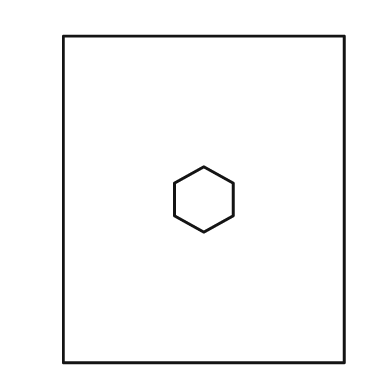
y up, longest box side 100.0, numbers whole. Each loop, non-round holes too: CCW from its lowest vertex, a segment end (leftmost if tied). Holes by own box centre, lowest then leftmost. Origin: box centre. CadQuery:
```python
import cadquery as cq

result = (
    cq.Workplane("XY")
    .moveTo(-43.0, -50.0)
    .lineTo(43.0, -50.0)
    .lineTo(43.0, 50.0)
    .lineTo(-43.0, 50.0)
    .close()
    .moveTo(0.0, -10.0)
    .lineTo(9.0, -5.0)
    .lineTo(9.0, 5.0)
    .lineTo(0.0, 10.0)
    .lineTo(-9.0, 5.0)
    .lineTo(-9.0, -5.0)
    .close()
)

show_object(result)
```